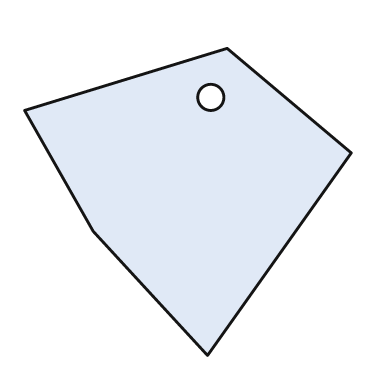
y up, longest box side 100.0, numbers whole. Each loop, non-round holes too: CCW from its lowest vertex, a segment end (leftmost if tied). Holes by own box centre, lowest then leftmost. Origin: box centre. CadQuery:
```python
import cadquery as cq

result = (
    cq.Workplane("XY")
    .moveTo(6.0, -47.0)
    .lineTo(50.0, 15.0)
    .lineTo(12.0, 47.0)
    .lineTo(-50.0, 28.0)
    .lineTo(-29.0, -9.0)
    .close()
    .moveTo(7.0, 32.0)
    .circle(4.0)
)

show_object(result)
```